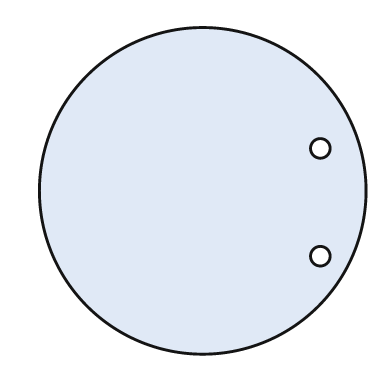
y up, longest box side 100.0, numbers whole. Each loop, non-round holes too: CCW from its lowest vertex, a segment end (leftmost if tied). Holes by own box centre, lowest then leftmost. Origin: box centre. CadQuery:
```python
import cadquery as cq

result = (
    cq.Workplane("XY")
    .moveTo(0.0, 0.0)
    .circle(50.0)
    .moveTo(36.0, -20.0)
    .circle(3.0)
    .moveTo(36.0, 13.0)
    .circle(3.0)
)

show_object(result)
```